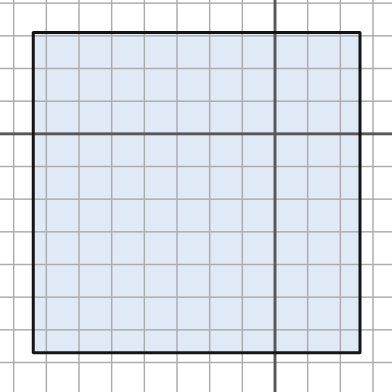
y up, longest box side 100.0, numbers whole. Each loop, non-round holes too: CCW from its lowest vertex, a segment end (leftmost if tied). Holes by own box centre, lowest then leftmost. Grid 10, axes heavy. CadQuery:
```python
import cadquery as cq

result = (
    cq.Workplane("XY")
    .moveTo(-74.0, -67.0)
    .lineTo(26.0, -67.0)
    .lineTo(26.0, 31.0)
    .lineTo(-74.0, 31.0)
    .close()
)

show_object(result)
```